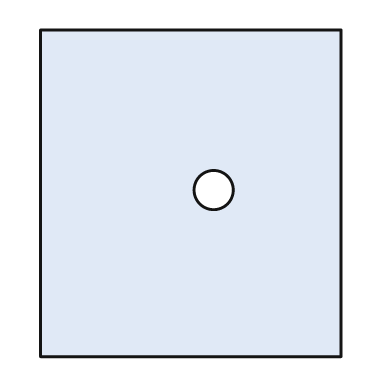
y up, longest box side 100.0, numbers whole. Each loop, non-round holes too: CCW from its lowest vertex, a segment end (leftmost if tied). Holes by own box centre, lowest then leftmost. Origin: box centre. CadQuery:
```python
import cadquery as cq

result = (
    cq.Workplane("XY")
    .moveTo(-46.0, -50.0)
    .lineTo(46.0, -50.0)
    .lineTo(46.0, 50.0)
    .lineTo(-46.0, 50.0)
    .close()
    .moveTo(7.0, 1.0)
    .circle(6.0)
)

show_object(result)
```